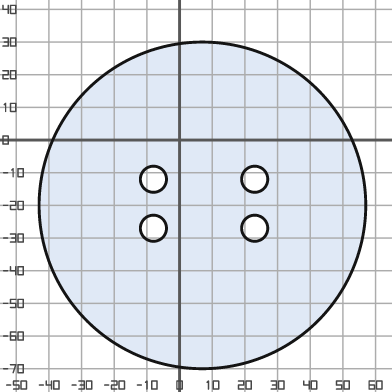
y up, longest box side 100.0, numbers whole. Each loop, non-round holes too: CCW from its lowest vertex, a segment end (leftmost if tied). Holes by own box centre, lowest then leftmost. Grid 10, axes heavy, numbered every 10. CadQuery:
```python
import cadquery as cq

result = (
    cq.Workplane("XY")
    .moveTo(7.0, -20.0)
    .circle(50.0)
    .moveTo(-8.0, -27.0)
    .circle(4.0)
    .moveTo(23.0, -27.0)
    .circle(4.0)
    .moveTo(-8.0, -12.0)
    .circle(4.0)
    .moveTo(23.0, -12.0)
    .circle(4.0)
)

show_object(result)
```